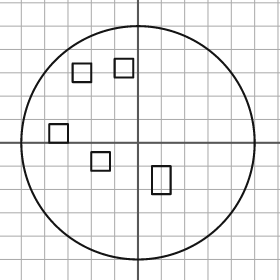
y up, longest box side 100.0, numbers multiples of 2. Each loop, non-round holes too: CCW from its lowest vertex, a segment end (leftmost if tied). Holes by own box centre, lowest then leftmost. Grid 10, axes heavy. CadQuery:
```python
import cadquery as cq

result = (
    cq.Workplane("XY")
    .moveTo(0.0, 0.0)
    .circle(50.0)
    .moveTo(6.0, -22.0)
    .lineTo(14.0, -22.0)
    .lineTo(14.0, -10.0)
    .lineTo(6.0, -10.0)
    .close()
    .moveTo(-20.0, -12.0)
    .lineTo(-12.0, -12.0)
    .lineTo(-12.0, -4.0)
    .lineTo(-20.0, -4.0)
    .close()
    .moveTo(-38.0, 0.0)
    .lineTo(-30.0, 0.0)
    .lineTo(-30.0, 8.0)
    .lineTo(-38.0, 8.0)
    .close()
    .moveTo(-28.0, 26.0)
    .lineTo(-20.0, 26.0)
    .lineTo(-20.0, 34.0)
    .lineTo(-28.0, 34.0)
    .close()
    .moveTo(-10.0, 28.0)
    .lineTo(-2.0, 28.0)
    .lineTo(-2.0, 36.0)
    .lineTo(-10.0, 36.0)
    .close()
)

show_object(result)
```